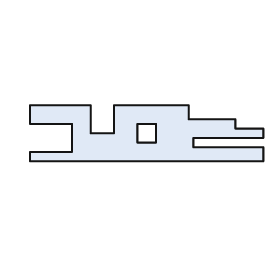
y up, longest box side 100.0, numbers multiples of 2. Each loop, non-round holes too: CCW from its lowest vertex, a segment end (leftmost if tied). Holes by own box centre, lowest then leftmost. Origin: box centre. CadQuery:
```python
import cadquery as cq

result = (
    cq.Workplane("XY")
    .moveTo(-50.0, -12.0)
    .lineTo(50.0, -12.0)
    .lineTo(50.0, -6.0)
    .lineTo(20.0, -6.0)
    .lineTo(20.0, -2.0)
    .lineTo(50.0, -2.0)
    .lineTo(50.0, 2.0)
    .lineTo(38.0, 2.0)
    .lineTo(38.0, 6.0)
    .lineTo(18.0, 6.0)
    .lineTo(18.0, 12.0)
    .lineTo(-14.0, 12.0)
    .lineTo(-14.0, 0.0)
    .lineTo(-24.0, 0.0)
    .lineTo(-24.0, 12.0)
    .lineTo(-50.0, 12.0)
    .lineTo(-50.0, 4.0)
    .lineTo(-32.0, 4.0)
    .lineTo(-32.0, -8.0)
    .lineTo(-50.0, -8.0)
    .close()
    .moveTo(-4.0, -4.0)
    .lineTo(4.0, -4.0)
    .lineTo(4.0, 4.0)
    .lineTo(-4.0, 4.0)
    .close()
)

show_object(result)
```